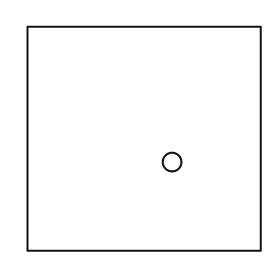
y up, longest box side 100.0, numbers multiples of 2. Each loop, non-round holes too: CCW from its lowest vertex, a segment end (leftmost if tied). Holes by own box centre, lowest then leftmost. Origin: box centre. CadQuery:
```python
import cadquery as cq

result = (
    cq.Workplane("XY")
    .moveTo(-50.0, -48.0)
    .lineTo(50.0, -48.0)
    .lineTo(50.0, 48.0)
    .lineTo(-50.0, 48.0)
    .close()
    .moveTo(12.0, -10.0)
    .circle(4.0)
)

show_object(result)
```